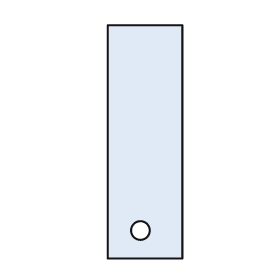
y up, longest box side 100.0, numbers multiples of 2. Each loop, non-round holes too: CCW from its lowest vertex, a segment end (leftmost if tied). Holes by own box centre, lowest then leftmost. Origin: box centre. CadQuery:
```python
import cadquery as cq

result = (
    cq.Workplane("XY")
    .moveTo(-16.0, -50.0)
    .lineTo(16.0, -50.0)
    .lineTo(16.0, 50.0)
    .lineTo(-16.0, 50.0)
    .close()
    .moveTo(-2.0, -38.0)
    .circle(4.0)
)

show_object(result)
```